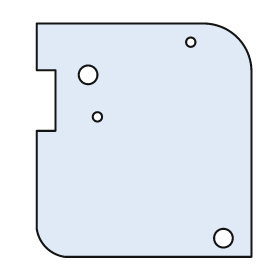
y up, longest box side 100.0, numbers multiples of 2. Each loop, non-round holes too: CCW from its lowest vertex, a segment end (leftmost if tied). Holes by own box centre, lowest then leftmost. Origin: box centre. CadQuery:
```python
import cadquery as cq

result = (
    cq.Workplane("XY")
    .moveTo(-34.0, -50.0)
    .lineTo(46.0, -50.0)
    .lineTo(46.0, 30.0)
    .threePointArc((40.0, 44.0), (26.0, 50.0))
    .lineTo(-46.0, 50.0)
    .lineTo(-46.0, 30.0)
    .lineTo(-38.0, 30.0)
    .lineTo(-38.0, 4.0)
    .lineTo(-46.0, 4.0)
    .lineTo(-46.0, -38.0)
    .threePointArc((-42.0, -46.0), (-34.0, -50.0))
    .close()
    .moveTo(34.0, -42.0)
    .circle(4.0)
    .moveTo(-20.0, 10.0)
    .circle(2.0)
    .moveTo(-24.0, 28.0)
    .circle(4.0)
    .moveTo(20.0, 42.0)
    .circle(2.0)
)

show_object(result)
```